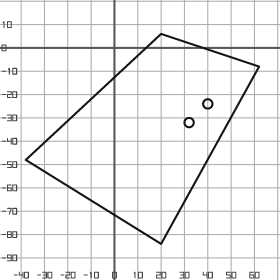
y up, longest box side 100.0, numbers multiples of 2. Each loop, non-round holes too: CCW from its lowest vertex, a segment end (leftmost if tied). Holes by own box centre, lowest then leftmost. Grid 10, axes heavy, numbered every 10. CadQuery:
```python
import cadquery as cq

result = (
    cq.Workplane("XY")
    .moveTo(20.0, -84.0)
    .lineTo(62.0, -8.0)
    .lineTo(20.0, 6.0)
    .lineTo(-38.0, -48.0)
    .close()
    .moveTo(32.0, -32.0)
    .circle(2.0)
    .moveTo(40.0, -24.0)
    .circle(2.0)
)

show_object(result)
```